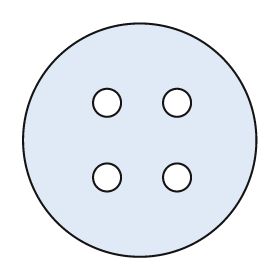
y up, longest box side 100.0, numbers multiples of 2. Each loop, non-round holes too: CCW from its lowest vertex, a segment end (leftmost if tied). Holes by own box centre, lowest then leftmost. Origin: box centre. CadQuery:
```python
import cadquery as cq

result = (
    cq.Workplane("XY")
    .moveTo(0.0, 0.0)
    .circle(50.0)
    .moveTo(-14.0, -16.0)
    .circle(6.0)
    .moveTo(16.0, -16.0)
    .circle(6.0)
    .moveTo(-14.0, 16.0)
    .circle(6.0)
    .moveTo(16.0, 16.0)
    .circle(6.0)
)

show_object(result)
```